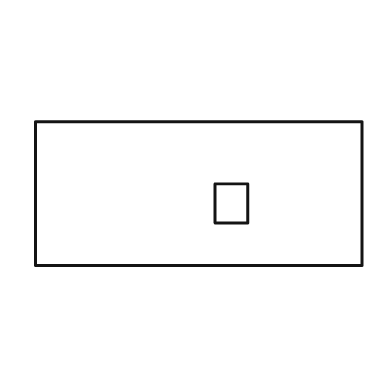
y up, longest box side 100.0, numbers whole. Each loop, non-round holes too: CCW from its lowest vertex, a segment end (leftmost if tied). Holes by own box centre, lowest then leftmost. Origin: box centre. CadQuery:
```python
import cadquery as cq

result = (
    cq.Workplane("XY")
    .moveTo(-50.0, -22.0)
    .lineTo(50.0, -22.0)
    .lineTo(50.0, 22.0)
    .lineTo(-50.0, 22.0)
    .close()
    .moveTo(5.0, -9.0)
    .lineTo(15.0, -9.0)
    .lineTo(15.0, 3.0)
    .lineTo(5.0, 3.0)
    .close()
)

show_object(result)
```